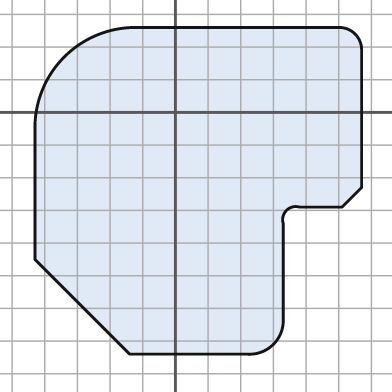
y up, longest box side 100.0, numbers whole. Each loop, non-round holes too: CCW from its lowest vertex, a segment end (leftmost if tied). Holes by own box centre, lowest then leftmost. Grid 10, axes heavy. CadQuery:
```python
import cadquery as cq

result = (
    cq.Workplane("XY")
    .moveTo(-14.0, -74.0)
    .lineTo(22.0, -74.0)
    .threePointArc((30.0, -71.0), (33.0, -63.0))
    .lineTo(33.0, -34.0)
    .threePointArc((34.0, -30.0), (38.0, -29.0))
    .lineTo(51.0, -29.0)
    .lineTo(57.0, -23.0)
    .lineTo(57.0, 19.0)
    .threePointArc((55.0, 24.0), (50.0, 26.0))
    .lineTo(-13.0, 26.0)
    .threePointArc((-34.0, 17.0), (-43.0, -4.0))
    .lineTo(-43.0, -45.0)
    .close()
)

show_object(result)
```